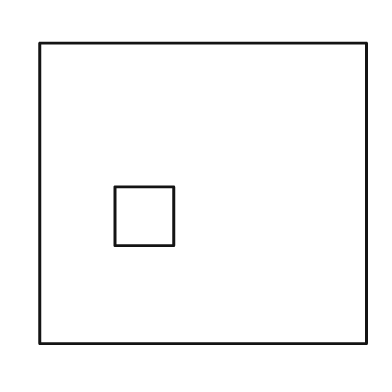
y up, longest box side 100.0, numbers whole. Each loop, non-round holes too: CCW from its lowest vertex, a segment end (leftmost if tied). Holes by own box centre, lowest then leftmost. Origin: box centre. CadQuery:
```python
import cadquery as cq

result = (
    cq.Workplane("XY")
    .moveTo(-50.0, -46.0)
    .lineTo(50.0, -46.0)
    .lineTo(50.0, 46.0)
    .lineTo(-50.0, 46.0)
    .close()
    .moveTo(-27.0, -16.0)
    .lineTo(-9.0, -16.0)
    .lineTo(-9.0, 2.0)
    .lineTo(-27.0, 2.0)
    .close()
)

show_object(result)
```